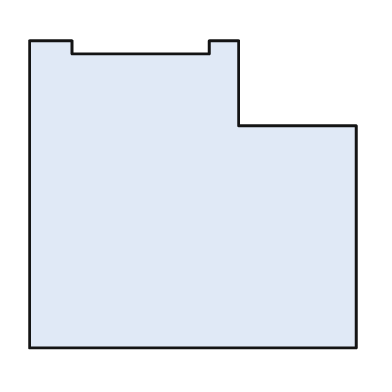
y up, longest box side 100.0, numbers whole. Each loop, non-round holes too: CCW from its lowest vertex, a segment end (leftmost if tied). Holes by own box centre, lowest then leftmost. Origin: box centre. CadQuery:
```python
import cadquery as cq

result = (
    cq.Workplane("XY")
    .moveTo(-50.0, -47.0)
    .lineTo(50.0, -47.0)
    .lineTo(50.0, 21.0)
    .lineTo(14.0, 21.0)
    .lineTo(14.0, 47.0)
    .lineTo(5.0, 47.0)
    .lineTo(5.0, 43.0)
    .lineTo(-37.0, 43.0)
    .lineTo(-37.0, 47.0)
    .lineTo(-50.0, 47.0)
    .close()
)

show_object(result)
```